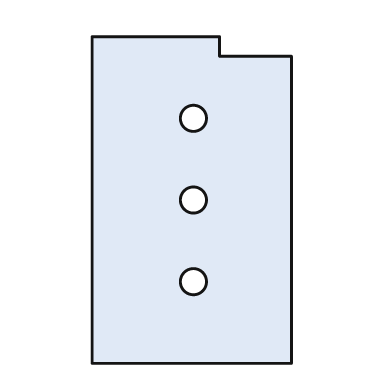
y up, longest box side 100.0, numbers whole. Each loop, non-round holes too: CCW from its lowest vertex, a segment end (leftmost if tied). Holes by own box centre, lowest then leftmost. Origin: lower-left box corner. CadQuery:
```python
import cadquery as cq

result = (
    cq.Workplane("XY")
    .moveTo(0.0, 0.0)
    .lineTo(61.0, 0.0)
    .lineTo(61.0, 94.0)
    .lineTo(39.0, 94.0)
    .lineTo(39.0, 100.0)
    .lineTo(0.0, 100.0)
    .close()
    .moveTo(31.0, 25.0)
    .circle(4.0)
    .moveTo(31.0, 50.0)
    .circle(4.0)
    .moveTo(31.0, 75.0)
    .circle(4.0)
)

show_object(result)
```